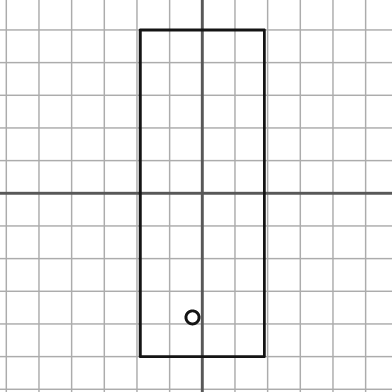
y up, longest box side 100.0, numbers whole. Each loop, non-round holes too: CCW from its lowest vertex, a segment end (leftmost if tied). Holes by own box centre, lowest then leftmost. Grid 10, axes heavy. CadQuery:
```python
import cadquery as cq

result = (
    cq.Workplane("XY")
    .moveTo(-19.0, -50.0)
    .lineTo(19.0, -50.0)
    .lineTo(19.0, 50.0)
    .lineTo(-19.0, 50.0)
    .close()
    .moveTo(-3.0, -38.0)
    .circle(2.0)
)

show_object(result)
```